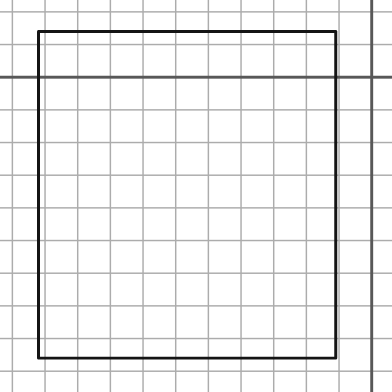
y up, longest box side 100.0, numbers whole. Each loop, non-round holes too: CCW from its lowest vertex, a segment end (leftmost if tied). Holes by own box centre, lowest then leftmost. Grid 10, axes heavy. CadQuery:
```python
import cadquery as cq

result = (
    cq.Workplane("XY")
    .moveTo(-102.0, -86.0)
    .lineTo(-11.0, -86.0)
    .lineTo(-11.0, 14.0)
    .lineTo(-102.0, 14.0)
    .close()
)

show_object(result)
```